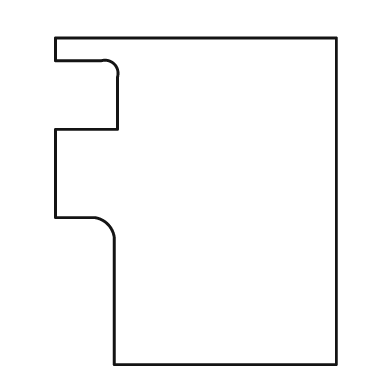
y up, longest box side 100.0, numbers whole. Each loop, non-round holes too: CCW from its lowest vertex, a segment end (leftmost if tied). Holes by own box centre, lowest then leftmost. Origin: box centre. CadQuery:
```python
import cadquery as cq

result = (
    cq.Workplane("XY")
    .moveTo(-25.0, -50.0)
    .lineTo(43.0, -50.0)
    .lineTo(43.0, 50.0)
    .lineTo(-43.0, 50.0)
    .lineTo(-43.0, 43.0)
    .lineTo(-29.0, 43.0)
    .threePointArc((-25.0, 42.0), (-24.0, 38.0))
    .lineTo(-24.0, 22.0)
    .lineTo(-43.0, 22.0)
    .lineTo(-43.0, -5.0)
    .lineTo(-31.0, -5.0)
    .threePointArc((-27.0, -7.0), (-25.0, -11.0))
    .close()
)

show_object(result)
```